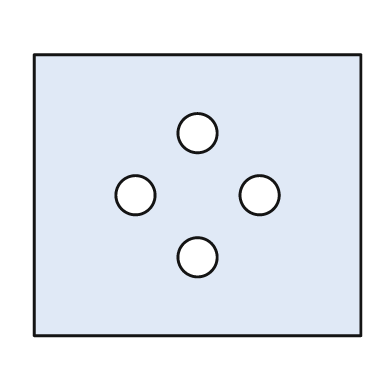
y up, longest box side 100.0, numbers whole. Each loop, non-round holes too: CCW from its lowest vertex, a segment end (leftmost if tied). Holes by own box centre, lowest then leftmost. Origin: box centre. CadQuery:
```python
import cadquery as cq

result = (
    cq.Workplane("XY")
    .moveTo(-50.0, -43.0)
    .lineTo(50.0, -43.0)
    .lineTo(50.0, 43.0)
    .lineTo(-50.0, 43.0)
    .close()
    .moveTo(0.0, -19.0)
    .circle(6.0)
    .moveTo(-19.0, 0.0)
    .circle(6.0)
    .moveTo(19.0, 0.0)
    .circle(6.0)
    .moveTo(0.0, 19.0)
    .circle(6.0)
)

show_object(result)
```